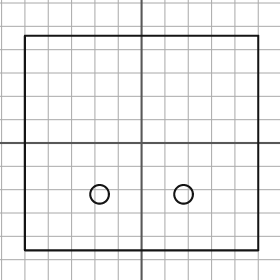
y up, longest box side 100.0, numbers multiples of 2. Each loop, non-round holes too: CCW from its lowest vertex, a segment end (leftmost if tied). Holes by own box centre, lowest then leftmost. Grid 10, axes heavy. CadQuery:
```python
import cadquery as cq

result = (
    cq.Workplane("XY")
    .moveTo(-50.0, -46.0)
    .lineTo(50.0, -46.0)
    .lineTo(50.0, 46.0)
    .lineTo(-50.0, 46.0)
    .close()
    .moveTo(-18.0, -22.0)
    .circle(4.0)
    .moveTo(18.0, -22.0)
    .circle(4.0)
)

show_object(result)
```